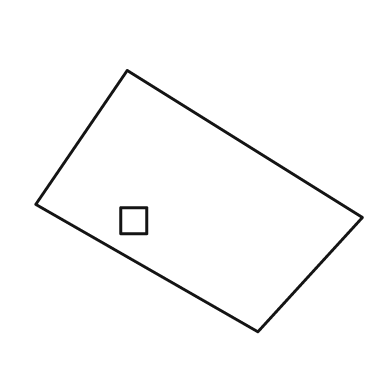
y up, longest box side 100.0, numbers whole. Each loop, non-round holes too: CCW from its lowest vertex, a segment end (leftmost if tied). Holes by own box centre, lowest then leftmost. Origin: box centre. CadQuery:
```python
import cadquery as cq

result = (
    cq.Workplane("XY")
    .moveTo(18.0, -40.0)
    .lineTo(50.0, -5.0)
    .lineTo(-22.0, 40.0)
    .lineTo(-50.0, -1.0)
    .close()
    .moveTo(-24.0, -10.0)
    .lineTo(-16.0, -10.0)
    .lineTo(-16.0, -2.0)
    .lineTo(-24.0, -2.0)
    .close()
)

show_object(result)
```